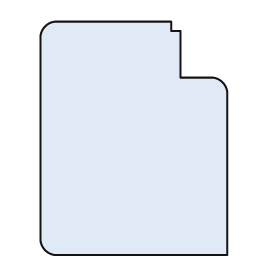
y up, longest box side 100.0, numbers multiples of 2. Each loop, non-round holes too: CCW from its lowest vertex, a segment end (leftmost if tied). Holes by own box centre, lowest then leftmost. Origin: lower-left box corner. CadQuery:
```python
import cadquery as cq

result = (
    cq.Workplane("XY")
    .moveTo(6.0, 0.0)
    .lineTo(80.0, 0.0)
    .lineTo(80.0, 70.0)
    .threePointArc((78.0, 74.0), (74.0, 76.0))
    .lineTo(60.0, 76.0)
    .lineTo(60.0, 96.0)
    .lineTo(56.0, 96.0)
    .lineTo(56.0, 100.0)
    .lineTo(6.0, 100.0)
    .threePointArc((2.0, 98.0), (0.0, 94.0))
    .lineTo(0.0, 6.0)
    .threePointArc((2.0, 2.0), (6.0, 0.0))
    .close()
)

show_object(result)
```